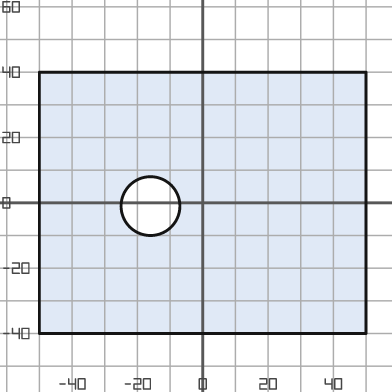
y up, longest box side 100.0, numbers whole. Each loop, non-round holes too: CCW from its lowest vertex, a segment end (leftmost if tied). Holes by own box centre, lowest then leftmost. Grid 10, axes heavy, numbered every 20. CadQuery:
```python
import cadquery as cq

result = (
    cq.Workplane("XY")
    .moveTo(-50.0, -40.0)
    .lineTo(50.0, -40.0)
    .lineTo(50.0, 40.0)
    .lineTo(-50.0, 40.0)
    .close()
    .moveTo(-16.0, -1.0)
    .circle(9.0)
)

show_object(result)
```